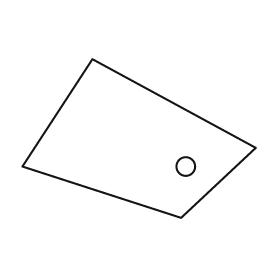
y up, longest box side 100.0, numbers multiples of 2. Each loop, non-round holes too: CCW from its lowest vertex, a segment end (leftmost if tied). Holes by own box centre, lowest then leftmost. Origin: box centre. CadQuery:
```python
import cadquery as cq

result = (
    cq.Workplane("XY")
    .moveTo(18.0, -34.0)
    .lineTo(50.0, -4.0)
    .lineTo(-20.0, 34.0)
    .lineTo(-50.0, -12.0)
    .close()
    .moveTo(20.0, -12.0)
    .circle(4.0)
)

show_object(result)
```